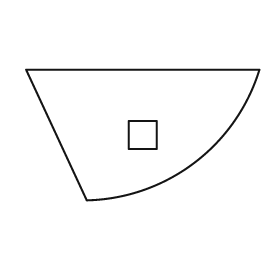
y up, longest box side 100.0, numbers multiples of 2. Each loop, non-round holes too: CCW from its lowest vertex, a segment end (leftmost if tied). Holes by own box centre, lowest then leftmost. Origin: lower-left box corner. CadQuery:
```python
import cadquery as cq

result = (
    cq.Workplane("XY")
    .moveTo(26.0, 0.0)
    .threePointArc((72.0, 16.0), (100.0, 56.0))
    .lineTo(0.0, 56.0)
    .close()
    .moveTo(44.0, 22.0)
    .lineTo(56.0, 22.0)
    .lineTo(56.0, 34.0)
    .lineTo(44.0, 34.0)
    .close()
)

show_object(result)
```